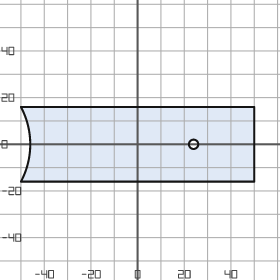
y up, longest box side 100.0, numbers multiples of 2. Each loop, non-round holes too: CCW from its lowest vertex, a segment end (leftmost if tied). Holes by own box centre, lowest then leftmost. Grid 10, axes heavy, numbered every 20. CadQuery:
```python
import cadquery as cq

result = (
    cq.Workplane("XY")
    .moveTo(-50.0, -16.0)
    .lineTo(50.0, -16.0)
    .lineTo(50.0, 16.0)
    .lineTo(-50.0, 16.0)
    .threePointArc((-46.0, 0.0), (-50.0, -16.0))
    .close()
    .moveTo(24.0, 0.0)
    .circle(2.0)
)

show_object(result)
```